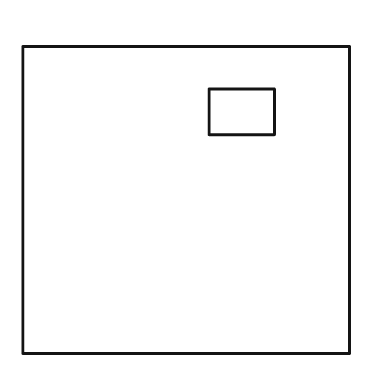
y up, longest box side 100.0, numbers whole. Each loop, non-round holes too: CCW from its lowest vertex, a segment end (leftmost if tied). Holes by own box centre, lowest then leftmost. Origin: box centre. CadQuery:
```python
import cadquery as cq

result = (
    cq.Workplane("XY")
    .moveTo(-50.0, -47.0)
    .lineTo(50.0, -47.0)
    .lineTo(50.0, 47.0)
    .lineTo(-50.0, 47.0)
    .close()
    .moveTo(7.0, 20.0)
    .lineTo(27.0, 20.0)
    .lineTo(27.0, 34.0)
    .lineTo(7.0, 34.0)
    .close()
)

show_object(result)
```